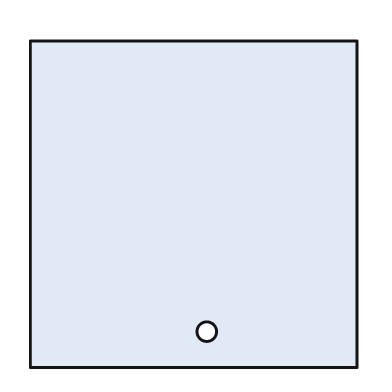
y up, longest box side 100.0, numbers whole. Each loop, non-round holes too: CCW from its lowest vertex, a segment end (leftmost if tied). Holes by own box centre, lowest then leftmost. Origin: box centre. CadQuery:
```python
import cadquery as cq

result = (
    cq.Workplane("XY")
    .moveTo(-50.0, -50.0)
    .lineTo(50.0, -50.0)
    .lineTo(50.0, 50.0)
    .lineTo(-50.0, 50.0)
    .close()
    .moveTo(4.0, -39.0)
    .circle(3.0)
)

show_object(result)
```